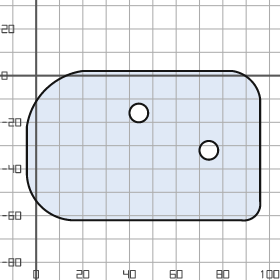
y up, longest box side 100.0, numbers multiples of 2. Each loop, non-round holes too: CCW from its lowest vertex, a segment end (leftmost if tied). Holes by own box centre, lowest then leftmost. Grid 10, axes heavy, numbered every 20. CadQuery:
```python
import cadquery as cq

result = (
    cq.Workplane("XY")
    .moveTo(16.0, -62.0)
    .lineTo(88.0, -62.0)
    .threePointArc((94.0, -60.0), (96.0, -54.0))
    .lineTo(96.0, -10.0)
    .threePointArc((92.0, -2.0), (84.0, 2.0))
    .lineTo(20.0, 2.0)
    .threePointArc((4.0, -6.0), (-4.0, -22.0))
    .lineTo(-4.0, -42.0)
    .threePointArc((2.0, -56.0), (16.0, -62.0))
    .close()
    .moveTo(74.0, -32.0)
    .circle(4.0)
    .moveTo(44.0, -16.0)
    .circle(4.0)
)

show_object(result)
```